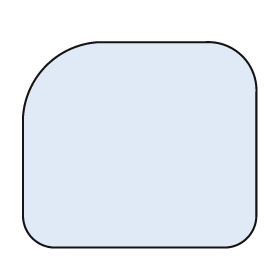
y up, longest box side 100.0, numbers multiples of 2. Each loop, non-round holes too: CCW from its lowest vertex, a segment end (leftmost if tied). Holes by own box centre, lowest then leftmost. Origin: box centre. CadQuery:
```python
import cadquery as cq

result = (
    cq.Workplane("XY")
    .moveTo(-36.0, -44.0)
    .lineTo(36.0, -44.0)
    .threePointArc((46.0, -40.0), (50.0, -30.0))
    .lineTo(50.0, 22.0)
    .threePointArc((44.0, 38.0), (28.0, 44.0))
    .lineTo(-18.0, 44.0)
    .threePointArc((-40.0, 34.0), (-50.0, 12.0))
    .lineTo(-50.0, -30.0)
    .threePointArc((-46.0, -40.0), (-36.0, -44.0))
    .close()
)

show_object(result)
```